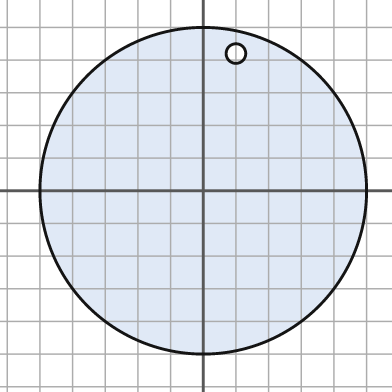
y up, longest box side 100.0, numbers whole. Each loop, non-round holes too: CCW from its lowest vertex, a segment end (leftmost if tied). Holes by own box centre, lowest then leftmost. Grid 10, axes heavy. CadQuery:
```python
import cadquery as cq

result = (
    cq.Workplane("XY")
    .moveTo(0.0, 0.0)
    .circle(50.0)
    .moveTo(10.0, 42.0)
    .circle(3.0)
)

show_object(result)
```